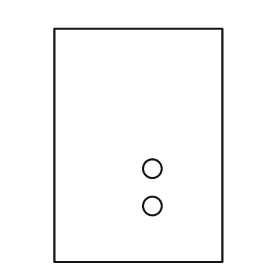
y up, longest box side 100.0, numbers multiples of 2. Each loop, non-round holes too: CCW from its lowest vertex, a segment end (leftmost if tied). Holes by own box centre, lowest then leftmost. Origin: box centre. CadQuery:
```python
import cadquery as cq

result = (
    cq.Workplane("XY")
    .moveTo(-36.0, -50.0)
    .lineTo(36.0, -50.0)
    .lineTo(36.0, 50.0)
    .lineTo(-36.0, 50.0)
    .close()
    .moveTo(6.0, -26.0)
    .circle(4.0)
    .moveTo(6.0, -10.0)
    .circle(4.0)
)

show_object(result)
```